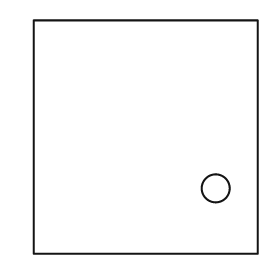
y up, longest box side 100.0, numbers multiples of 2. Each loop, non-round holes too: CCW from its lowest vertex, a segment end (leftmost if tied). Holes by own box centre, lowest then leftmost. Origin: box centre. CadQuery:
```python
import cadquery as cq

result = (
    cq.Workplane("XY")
    .moveTo(-48.0, -50.0)
    .lineTo(48.0, -50.0)
    .lineTo(48.0, 50.0)
    .lineTo(-48.0, 50.0)
    .close()
    .moveTo(30.0, -22.0)
    .circle(6.0)
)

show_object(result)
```